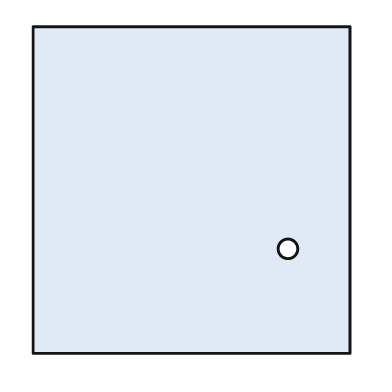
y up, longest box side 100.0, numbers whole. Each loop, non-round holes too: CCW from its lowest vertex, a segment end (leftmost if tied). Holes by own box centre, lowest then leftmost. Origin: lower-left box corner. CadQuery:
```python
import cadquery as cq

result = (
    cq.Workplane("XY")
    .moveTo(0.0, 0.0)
    .lineTo(97.0, 0.0)
    .lineTo(97.0, 100.0)
    .lineTo(0.0, 100.0)
    .close()
    .moveTo(78.0, 32.0)
    .circle(3.0)
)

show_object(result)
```